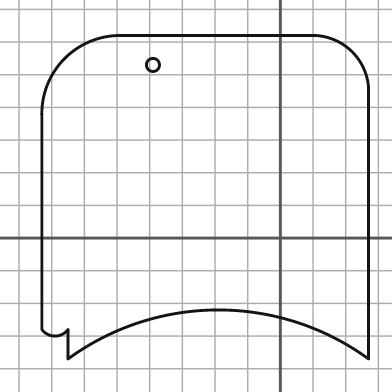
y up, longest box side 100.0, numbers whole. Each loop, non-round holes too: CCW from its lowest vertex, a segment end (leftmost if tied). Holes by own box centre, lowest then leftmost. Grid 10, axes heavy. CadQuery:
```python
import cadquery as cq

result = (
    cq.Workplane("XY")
    .moveTo(-65.0, -37.0)
    .threePointArc((-19.0, -22.0), (27.0, -37.0))
    .lineTo(27.0, 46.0)
    .threePointArc((22.0, 57.0), (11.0, 62.0))
    .lineTo(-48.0, 62.0)
    .threePointArc((-66.0, 55.0), (-73.0, 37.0))
    .lineTo(-73.0, -28.0)
    .threePointArc((-69.0, -30.0), (-65.0, -28.0))
    .close()
    .moveTo(-39.0, 53.0)
    .circle(2.0)
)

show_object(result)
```